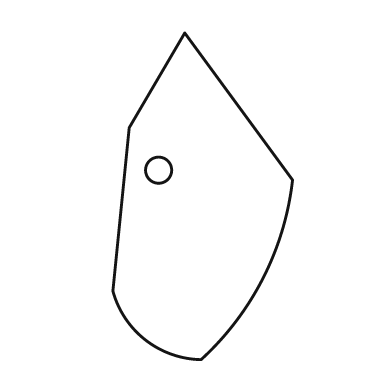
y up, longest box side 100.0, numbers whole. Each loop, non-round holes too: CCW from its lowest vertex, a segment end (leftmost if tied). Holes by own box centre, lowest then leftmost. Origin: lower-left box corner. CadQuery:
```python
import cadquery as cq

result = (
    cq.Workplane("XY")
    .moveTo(27.0, 0.0)
    .threePointArc((46.0, 25.0), (55.0, 55.0))
    .lineTo(22.0, 100.0)
    .lineTo(5.0, 71.0)
    .lineTo(0.0, 21.0)
    .threePointArc((10.0, 6.0), (27.0, 0.0))
    .close()
    .moveTo(14.0, 58.0)
    .circle(4.0)
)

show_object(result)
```